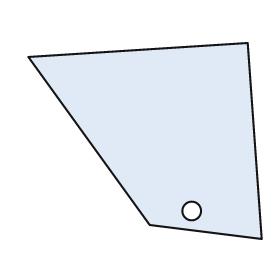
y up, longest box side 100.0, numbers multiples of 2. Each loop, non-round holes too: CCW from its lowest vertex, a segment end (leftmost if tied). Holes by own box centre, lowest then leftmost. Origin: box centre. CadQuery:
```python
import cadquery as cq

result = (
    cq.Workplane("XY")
    .moveTo(50.0, -42.0)
    .lineTo(44.0, 42.0)
    .lineTo(-50.0, 36.0)
    .lineTo(2.0, -36.0)
    .close()
    .moveTo(20.0, -30.0)
    .circle(4.0)
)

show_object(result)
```